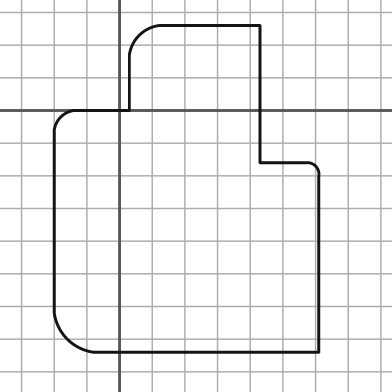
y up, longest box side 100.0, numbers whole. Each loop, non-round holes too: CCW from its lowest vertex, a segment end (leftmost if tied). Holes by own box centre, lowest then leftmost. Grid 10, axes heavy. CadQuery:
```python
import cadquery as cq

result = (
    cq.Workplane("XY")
    .moveTo(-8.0, -74.0)
    .lineTo(61.0, -74.0)
    .lineTo(61.0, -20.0)
    .threePointArc((60.0, -17.0), (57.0, -16.0))
    .lineTo(43.0, -16.0)
    .lineTo(43.0, 26.0)
    .lineTo(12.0, 26.0)
    .threePointArc((6.0, 23.0), (3.0, 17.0))
    .lineTo(3.0, 0.0)
    .lineTo(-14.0, 0.0)
    .threePointArc((-18.0, -2.0), (-20.0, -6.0))
    .lineTo(-20.0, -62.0)
    .threePointArc((-16.0, -70.0), (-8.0, -74.0))
    .close()
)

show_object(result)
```